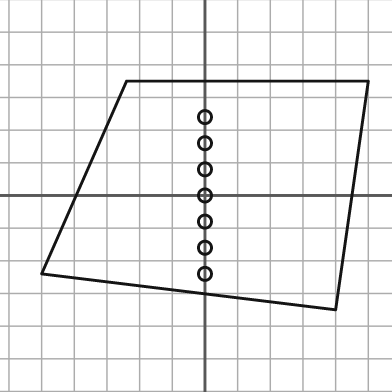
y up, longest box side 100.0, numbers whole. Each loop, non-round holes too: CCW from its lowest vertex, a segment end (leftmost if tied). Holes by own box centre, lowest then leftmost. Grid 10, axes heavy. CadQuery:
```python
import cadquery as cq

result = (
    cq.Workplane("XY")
    .moveTo(40.0, -35.0)
    .lineTo(50.0, 35.0)
    .lineTo(-24.0, 35.0)
    .lineTo(-50.0, -24.0)
    .close()
    .moveTo(0.0, -24.0)
    .circle(2.0)
    .moveTo(0.0, -16.0)
    .circle(2.0)
    .moveTo(0.0, -8.0)
    .circle(2.0)
    .moveTo(0.0, 0.0)
    .circle(2.0)
    .moveTo(0.0, 8.0)
    .circle(2.0)
    .moveTo(0.0, 16.0)
    .circle(2.0)
    .moveTo(0.0, 24.0)
    .circle(2.0)
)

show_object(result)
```